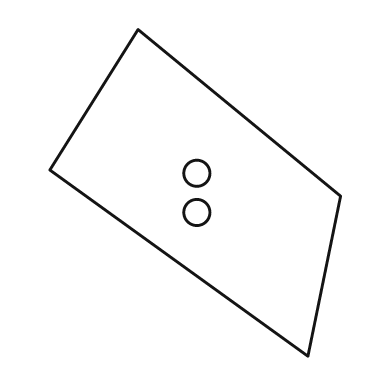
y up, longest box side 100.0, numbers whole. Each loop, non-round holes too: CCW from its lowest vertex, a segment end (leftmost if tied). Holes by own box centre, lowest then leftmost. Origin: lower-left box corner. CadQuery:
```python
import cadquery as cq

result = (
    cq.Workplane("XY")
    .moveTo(79.0, 0.0)
    .lineTo(89.0, 49.0)
    .lineTo(27.0, 100.0)
    .lineTo(0.0, 57.0)
    .close()
    .moveTo(45.0, 44.0)
    .circle(4.0)
    .moveTo(45.0, 56.0)
    .circle(4.0)
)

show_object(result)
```